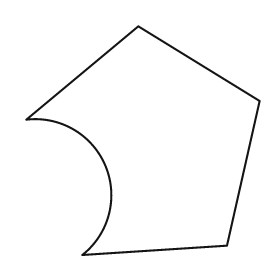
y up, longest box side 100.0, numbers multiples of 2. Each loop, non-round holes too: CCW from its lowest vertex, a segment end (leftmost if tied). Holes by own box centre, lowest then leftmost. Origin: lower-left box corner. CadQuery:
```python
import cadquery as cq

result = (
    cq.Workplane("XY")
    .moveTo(24.0, 0.0)
    .lineTo(86.0, 4.0)
    .lineTo(100.0, 66.0)
    .lineTo(48.0, 98.0)
    .lineTo(0.0, 58.0)
    .threePointArc((34.0, 38.0), (24.0, 0.0))
    .close()
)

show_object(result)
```